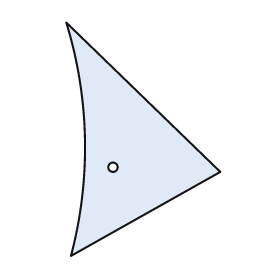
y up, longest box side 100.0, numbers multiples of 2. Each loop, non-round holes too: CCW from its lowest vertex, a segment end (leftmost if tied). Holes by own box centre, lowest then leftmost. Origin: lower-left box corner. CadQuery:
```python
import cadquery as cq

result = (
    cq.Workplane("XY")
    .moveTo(2.0, 0.0)
    .lineTo(66.0, 36.0)
    .lineTo(0.0, 100.0)
    .threePointArc((8.0, 50.0), (2.0, 0.0))
    .close()
    .moveTo(20.0, 38.0)
    .circle(2.0)
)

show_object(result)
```